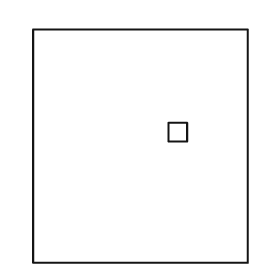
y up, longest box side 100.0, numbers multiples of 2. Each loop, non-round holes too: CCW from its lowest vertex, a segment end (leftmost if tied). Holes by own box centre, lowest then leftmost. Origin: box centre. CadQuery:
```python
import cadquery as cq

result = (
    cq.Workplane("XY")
    .moveTo(-46.0, -50.0)
    .lineTo(46.0, -50.0)
    .lineTo(46.0, 50.0)
    .lineTo(-46.0, 50.0)
    .close()
    .moveTo(12.0, 2.0)
    .lineTo(20.0, 2.0)
    .lineTo(20.0, 10.0)
    .lineTo(12.0, 10.0)
    .close()
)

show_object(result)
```